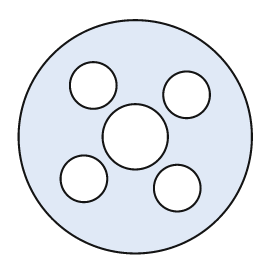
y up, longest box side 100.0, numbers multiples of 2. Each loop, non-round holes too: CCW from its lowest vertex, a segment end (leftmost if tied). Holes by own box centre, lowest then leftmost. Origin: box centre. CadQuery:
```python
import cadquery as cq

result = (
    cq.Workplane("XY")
    .moveTo(0.0, 0.0)
    .circle(50.0)
    .moveTo(18.0, -22.0)
    .circle(10.0)
    .moveTo(-22.0, -18.0)
    .circle(10.0)
    .moveTo(0.0, 0.0)
    .circle(14.0)
    .moveTo(22.0, 18.0)
    .circle(10.0)
    .moveTo(-18.0, 22.0)
    .circle(10.0)
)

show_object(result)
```